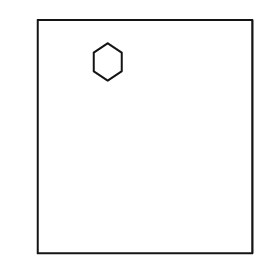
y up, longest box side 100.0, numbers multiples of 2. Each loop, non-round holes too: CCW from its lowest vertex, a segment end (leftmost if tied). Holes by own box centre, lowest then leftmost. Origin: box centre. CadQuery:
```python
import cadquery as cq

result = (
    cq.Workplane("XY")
    .moveTo(-46.0, -50.0)
    .lineTo(46.0, -50.0)
    .lineTo(46.0, 50.0)
    .lineTo(-46.0, 50.0)
    .close()
    .moveTo(-16.0, 24.0)
    .lineTo(-10.0, 28.0)
    .lineTo(-10.0, 36.0)
    .lineTo(-16.0, 40.0)
    .lineTo(-22.0, 36.0)
    .lineTo(-22.0, 28.0)
    .close()
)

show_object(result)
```